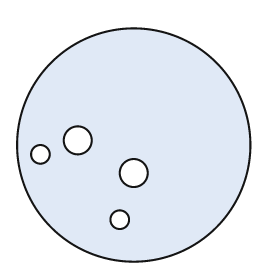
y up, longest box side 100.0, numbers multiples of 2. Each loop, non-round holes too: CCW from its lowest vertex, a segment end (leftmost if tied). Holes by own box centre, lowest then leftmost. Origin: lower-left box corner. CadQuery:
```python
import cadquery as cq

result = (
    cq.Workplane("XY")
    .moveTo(50.0, 50.0)
    .circle(50.0)
    .moveTo(44.0, 18.0)
    .circle(4.0)
    .moveTo(50.0, 38.0)
    .circle(6.0)
    .moveTo(10.0, 46.0)
    .circle(4.0)
    .moveTo(26.0, 52.0)
    .circle(6.0)
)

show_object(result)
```